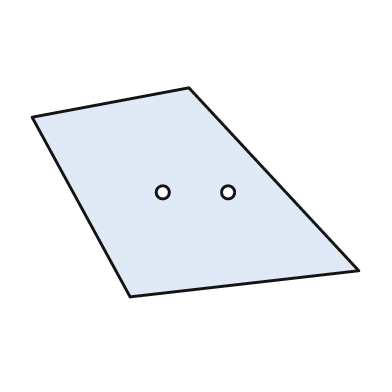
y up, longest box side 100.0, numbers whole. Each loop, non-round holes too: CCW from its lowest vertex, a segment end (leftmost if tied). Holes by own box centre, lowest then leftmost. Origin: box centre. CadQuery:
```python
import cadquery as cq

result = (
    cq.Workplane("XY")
    .moveTo(-20.0, -32.0)
    .lineTo(50.0, -24.0)
    .lineTo(-2.0, 32.0)
    .lineTo(-50.0, 23.0)
    .close()
    .moveTo(-10.0, 0.0)
    .circle(2.0)
    .moveTo(10.0, 0.0)
    .circle(2.0)
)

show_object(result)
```